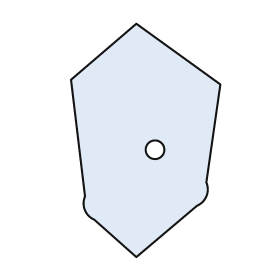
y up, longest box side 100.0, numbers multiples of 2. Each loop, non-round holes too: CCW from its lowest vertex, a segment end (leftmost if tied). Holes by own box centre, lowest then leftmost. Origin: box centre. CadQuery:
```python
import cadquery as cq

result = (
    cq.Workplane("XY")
    .moveTo(-4.0, -50.0)
    .lineTo(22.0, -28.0)
    .threePointArc((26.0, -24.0), (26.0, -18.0))
    .lineTo(32.0, 24.0)
    .lineTo(-4.0, 50.0)
    .lineTo(-32.0, 26.0)
    .lineTo(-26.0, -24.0)
    .threePointArc((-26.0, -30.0), (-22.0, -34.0))
    .close()
    .moveTo(4.0, -4.0)
    .circle(4.0)
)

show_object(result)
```